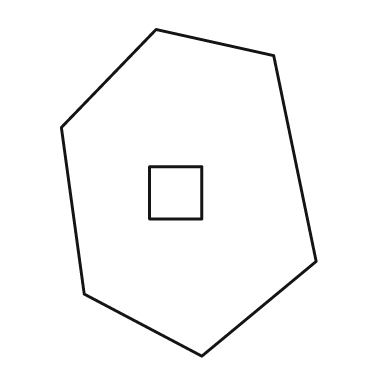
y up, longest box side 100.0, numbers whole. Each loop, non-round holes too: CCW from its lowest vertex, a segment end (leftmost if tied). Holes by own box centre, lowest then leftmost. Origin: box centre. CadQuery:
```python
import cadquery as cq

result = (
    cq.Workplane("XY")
    .moveTo(4.0, -50.0)
    .lineTo(39.0, -21.0)
    .lineTo(26.0, 42.0)
    .lineTo(-10.0, 50.0)
    .lineTo(-39.0, 20.0)
    .lineTo(-32.0, -31.0)
    .close()
    .moveTo(-12.0, -8.0)
    .lineTo(4.0, -8.0)
    .lineTo(4.0, 8.0)
    .lineTo(-12.0, 8.0)
    .close()
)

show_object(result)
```